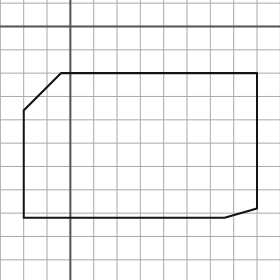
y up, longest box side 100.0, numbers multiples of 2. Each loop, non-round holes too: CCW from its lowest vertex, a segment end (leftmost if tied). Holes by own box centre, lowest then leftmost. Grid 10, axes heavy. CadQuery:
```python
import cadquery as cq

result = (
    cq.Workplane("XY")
    .moveTo(-20.0, -82.0)
    .lineTo(66.0, -82.0)
    .lineTo(80.0, -78.0)
    .lineTo(80.0, -20.0)
    .lineTo(-4.0, -20.0)
    .lineTo(-20.0, -36.0)
    .close()
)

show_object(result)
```